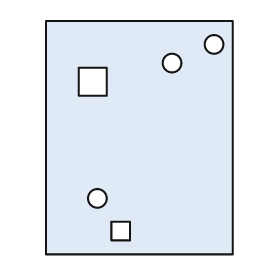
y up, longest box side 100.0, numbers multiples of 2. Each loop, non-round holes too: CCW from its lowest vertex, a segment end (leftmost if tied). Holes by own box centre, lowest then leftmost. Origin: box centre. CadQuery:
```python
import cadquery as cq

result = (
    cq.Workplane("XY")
    .moveTo(-40.0, -50.0)
    .lineTo(40.0, -50.0)
    .lineTo(40.0, 50.0)
    .lineTo(-40.0, 50.0)
    .close()
    .moveTo(-12.0, -44.0)
    .lineTo(-4.0, -44.0)
    .lineTo(-4.0, -36.0)
    .lineTo(-12.0, -36.0)
    .close()
    .moveTo(-18.0, -26.0)
    .circle(4.0)
    .moveTo(-26.0, 18.0)
    .lineTo(-14.0, 18.0)
    .lineTo(-14.0, 30.0)
    .lineTo(-26.0, 30.0)
    .close()
    .moveTo(14.0, 32.0)
    .circle(4.0)
    .moveTo(32.0, 40.0)
    .circle(4.0)
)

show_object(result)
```